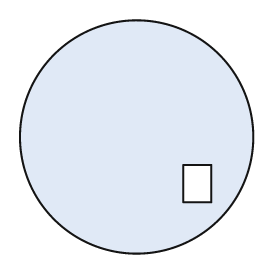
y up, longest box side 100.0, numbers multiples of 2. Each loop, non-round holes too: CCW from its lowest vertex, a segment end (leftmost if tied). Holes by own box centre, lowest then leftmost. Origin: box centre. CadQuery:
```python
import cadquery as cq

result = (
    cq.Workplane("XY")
    .moveTo(0.0, 0.0)
    .circle(50.0)
    .moveTo(20.0, -28.0)
    .lineTo(32.0, -28.0)
    .lineTo(32.0, -12.0)
    .lineTo(20.0, -12.0)
    .close()
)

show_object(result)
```